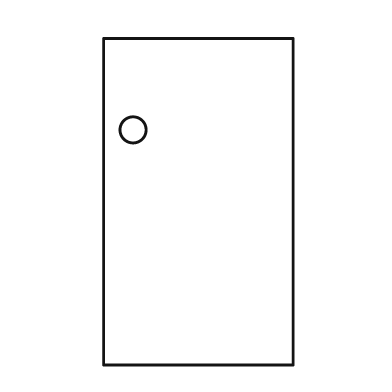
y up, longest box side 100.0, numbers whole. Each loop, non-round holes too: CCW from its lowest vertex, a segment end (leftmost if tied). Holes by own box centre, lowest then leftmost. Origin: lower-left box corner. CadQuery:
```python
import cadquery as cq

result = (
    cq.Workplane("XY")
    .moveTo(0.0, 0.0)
    .lineTo(58.0, 0.0)
    .lineTo(58.0, 100.0)
    .lineTo(0.0, 100.0)
    .close()
    .moveTo(9.0, 72.0)
    .circle(4.0)
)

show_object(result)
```